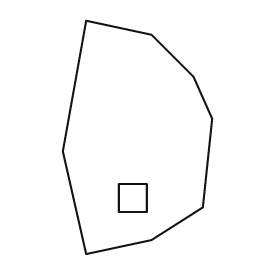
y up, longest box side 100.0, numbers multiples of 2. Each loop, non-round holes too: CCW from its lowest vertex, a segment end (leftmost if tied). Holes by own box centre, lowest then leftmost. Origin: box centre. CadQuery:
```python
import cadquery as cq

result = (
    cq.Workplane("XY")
    .moveTo(-22.0, -50.0)
    .lineTo(6.0, -44.0)
    .lineTo(28.0, -30.0)
    .lineTo(32.0, 8.0)
    .lineTo(24.0, 26.0)
    .lineTo(6.0, 44.0)
    .lineTo(-22.0, 50.0)
    .lineTo(-32.0, -6.0)
    .close()
    .moveTo(-8.0, -32.0)
    .lineTo(4.0, -32.0)
    .lineTo(4.0, -20.0)
    .lineTo(-8.0, -20.0)
    .close()
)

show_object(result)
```